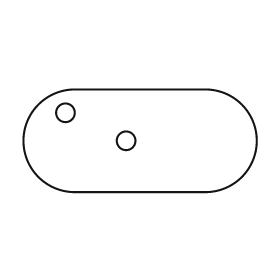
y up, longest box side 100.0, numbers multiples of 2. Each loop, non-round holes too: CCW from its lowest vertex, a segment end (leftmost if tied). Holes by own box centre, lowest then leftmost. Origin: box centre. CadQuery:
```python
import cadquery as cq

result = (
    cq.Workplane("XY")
    .moveTo(-28.0, -22.0)
    .lineTo(28.0, -22.0)
    .threePointArc((50.0, 0.0), (28.0, 22.0))
    .lineTo(-28.0, 22.0)
    .threePointArc((-50.0, 0.0), (-28.0, -22.0))
    .close()
    .moveTo(-6.0, 0.0)
    .circle(4.0)
    .moveTo(-32.0, 12.0)
    .circle(4.0)
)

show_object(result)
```